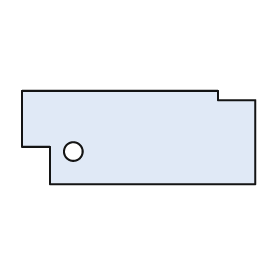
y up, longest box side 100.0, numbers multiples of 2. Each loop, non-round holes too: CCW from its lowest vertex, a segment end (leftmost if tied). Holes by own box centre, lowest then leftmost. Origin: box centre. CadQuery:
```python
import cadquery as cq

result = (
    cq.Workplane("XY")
    .moveTo(-38.0, -20.0)
    .lineTo(50.0, -20.0)
    .lineTo(50.0, 16.0)
    .lineTo(34.0, 16.0)
    .lineTo(34.0, 20.0)
    .lineTo(-50.0, 20.0)
    .lineTo(-50.0, -4.0)
    .lineTo(-38.0, -4.0)
    .close()
    .moveTo(-28.0, -6.0)
    .circle(4.0)
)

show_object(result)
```